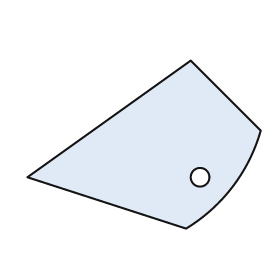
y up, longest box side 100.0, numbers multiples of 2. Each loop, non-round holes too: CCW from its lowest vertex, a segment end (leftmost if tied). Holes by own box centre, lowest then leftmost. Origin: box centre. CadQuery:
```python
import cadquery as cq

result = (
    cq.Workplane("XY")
    .moveTo(18.0, -36.0)
    .threePointArc((38.0, -18.0), (50.0, 6.0))
    .lineTo(20.0, 36.0)
    .lineTo(-50.0, -14.0)
    .close()
    .moveTo(24.0, -14.0)
    .circle(4.0)
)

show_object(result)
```